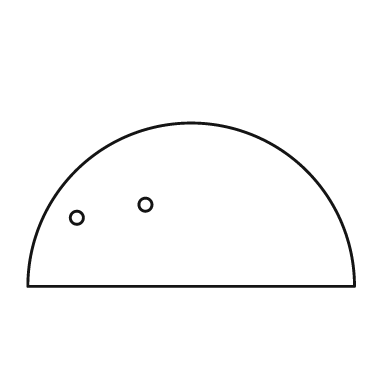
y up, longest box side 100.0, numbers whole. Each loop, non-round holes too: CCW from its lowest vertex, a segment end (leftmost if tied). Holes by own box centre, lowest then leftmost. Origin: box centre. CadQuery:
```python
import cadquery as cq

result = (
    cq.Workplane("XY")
    .moveTo(-50.0, -25.0)
    .lineTo(50.0, -25.0)
    .threePointArc((0.0, 25.0), (-50.0, -25.0))
    .close()
    .moveTo(-35.0, -4.0)
    .circle(2.0)
    .moveTo(-14.0, 0.0)
    .circle(2.0)
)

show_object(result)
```